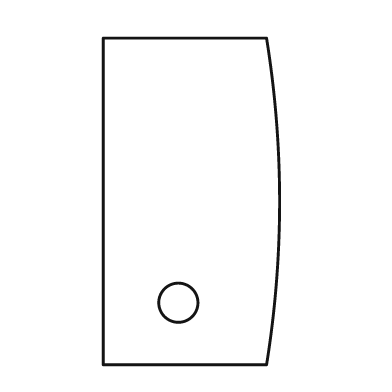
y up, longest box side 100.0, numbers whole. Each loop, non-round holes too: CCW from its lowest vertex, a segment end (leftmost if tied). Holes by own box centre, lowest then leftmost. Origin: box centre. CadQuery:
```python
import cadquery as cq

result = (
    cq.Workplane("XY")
    .moveTo(-27.0, -50.0)
    .lineTo(23.0, -50.0)
    .threePointArc((27.0, 0.0), (23.0, 50.0))
    .lineTo(-27.0, 50.0)
    .close()
    .moveTo(-4.0, -31.0)
    .circle(6.0)
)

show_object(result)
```